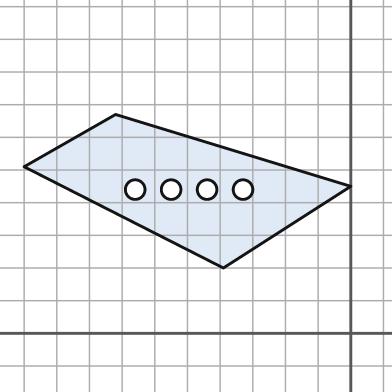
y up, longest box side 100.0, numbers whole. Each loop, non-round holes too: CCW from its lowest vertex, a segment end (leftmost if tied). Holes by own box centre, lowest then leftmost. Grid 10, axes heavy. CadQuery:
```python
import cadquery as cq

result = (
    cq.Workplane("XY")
    .moveTo(-39.0, 20.0)
    .lineTo(0.0, 45.0)
    .lineTo(-72.0, 67.0)
    .lineTo(-100.0, 51.0)
    .close()
    .moveTo(-66.0, 44.0)
    .circle(3.0)
    .moveTo(-55.0, 44.0)
    .circle(3.0)
    .moveTo(-44.0, 44.0)
    .circle(3.0)
    .moveTo(-33.0, 44.0)
    .circle(3.0)
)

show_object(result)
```